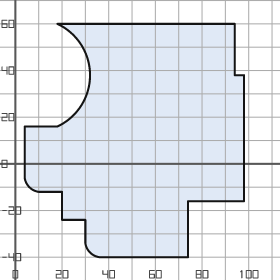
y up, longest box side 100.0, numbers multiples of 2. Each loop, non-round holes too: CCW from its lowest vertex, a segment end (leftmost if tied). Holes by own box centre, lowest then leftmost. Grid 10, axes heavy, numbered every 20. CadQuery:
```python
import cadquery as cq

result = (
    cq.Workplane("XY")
    .moveTo(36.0, -40.0)
    .lineTo(74.0, -40.0)
    .lineTo(74.0, -16.0)
    .lineTo(98.0, -16.0)
    .lineTo(98.0, 38.0)
    .lineTo(94.0, 38.0)
    .lineTo(94.0, 60.0)
    .lineTo(18.0, 60.0)
    .threePointArc((32.0, 38.0), (18.0, 16.0))
    .lineTo(4.0, 16.0)
    .lineTo(4.0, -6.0)
    .threePointArc((6.0, -10.0), (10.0, -12.0))
    .lineTo(20.0, -12.0)
    .lineTo(20.0, -24.0)
    .lineTo(30.0, -24.0)
    .lineTo(30.0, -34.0)
    .threePointArc((32.0, -38.0), (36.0, -40.0))
    .close()
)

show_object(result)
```